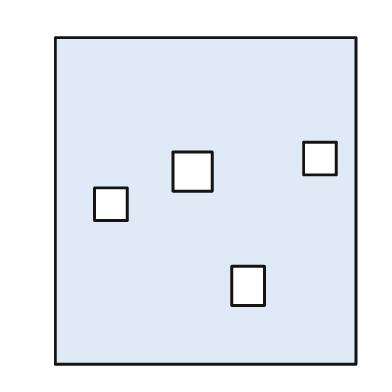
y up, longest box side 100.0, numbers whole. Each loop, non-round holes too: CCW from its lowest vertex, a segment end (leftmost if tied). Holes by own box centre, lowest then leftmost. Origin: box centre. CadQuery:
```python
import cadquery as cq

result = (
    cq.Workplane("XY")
    .moveTo(-46.0, -50.0)
    .lineTo(46.0, -50.0)
    .lineTo(46.0, 50.0)
    .lineTo(-46.0, 50.0)
    .close()
    .moveTo(8.0, -32.0)
    .lineTo(18.0, -32.0)
    .lineTo(18.0, -20.0)
    .lineTo(8.0, -20.0)
    .close()
    .moveTo(-34.0, -6.0)
    .lineTo(-24.0, -6.0)
    .lineTo(-24.0, 4.0)
    .lineTo(-34.0, 4.0)
    .close()
    .moveTo(-10.0, 3.0)
    .lineTo(2.0, 3.0)
    .lineTo(2.0, 15.0)
    .lineTo(-10.0, 15.0)
    .close()
    .moveTo(30.0, 8.0)
    .lineTo(40.0, 8.0)
    .lineTo(40.0, 18.0)
    .lineTo(30.0, 18.0)
    .close()
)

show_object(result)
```